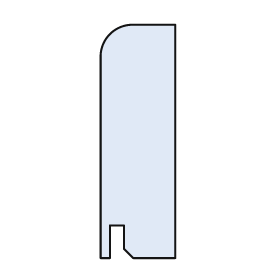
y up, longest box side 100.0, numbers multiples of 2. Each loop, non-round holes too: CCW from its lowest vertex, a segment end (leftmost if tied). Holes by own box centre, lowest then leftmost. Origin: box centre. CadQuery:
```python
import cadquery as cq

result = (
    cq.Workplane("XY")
    .moveTo(-16.0, -50.0)
    .lineTo(-12.0, -50.0)
    .lineTo(-12.0, -36.0)
    .lineTo(-6.0, -36.0)
    .lineTo(-6.0, -46.0)
    .lineTo(-2.0, -50.0)
    .lineTo(16.0, -50.0)
    .lineTo(16.0, 50.0)
    .lineTo(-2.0, 50.0)
    .threePointArc((-12.0, 46.0), (-16.0, 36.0))
    .close()
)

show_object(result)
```